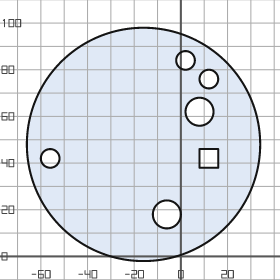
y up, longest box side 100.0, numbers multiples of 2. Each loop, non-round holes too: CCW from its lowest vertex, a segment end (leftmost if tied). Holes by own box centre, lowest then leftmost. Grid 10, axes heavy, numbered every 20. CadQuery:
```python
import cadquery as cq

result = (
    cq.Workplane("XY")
    .moveTo(-16.0, 48.0)
    .circle(50.0)
    .moveTo(-6.0, 18.0)
    .circle(6.0)
    .moveTo(-56.0, 42.0)
    .circle(4.0)
    .moveTo(8.0, 38.0)
    .lineTo(16.0, 38.0)
    .lineTo(16.0, 46.0)
    .lineTo(8.0, 46.0)
    .close()
    .moveTo(8.0, 62.0)
    .circle(6.0)
    .moveTo(12.0, 76.0)
    .circle(4.0)
    .moveTo(2.0, 84.0)
    .circle(4.0)
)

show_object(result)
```